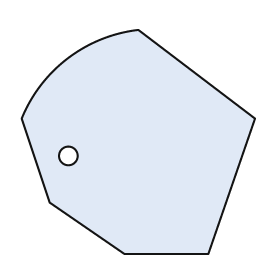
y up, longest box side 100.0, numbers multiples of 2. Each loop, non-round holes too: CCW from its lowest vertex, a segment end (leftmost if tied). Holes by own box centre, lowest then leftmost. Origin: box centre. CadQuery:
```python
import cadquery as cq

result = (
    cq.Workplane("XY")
    .moveTo(-6.0, -48.0)
    .lineTo(30.0, -48.0)
    .lineTo(50.0, 10.0)
    .lineTo(0.0, 48.0)
    .threePointArc((-30.0, 36.0), (-50.0, 10.0))
    .lineTo(-38.0, -26.0)
    .close()
    .moveTo(-30.0, -6.0)
    .circle(4.0)
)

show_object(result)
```